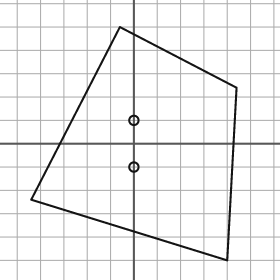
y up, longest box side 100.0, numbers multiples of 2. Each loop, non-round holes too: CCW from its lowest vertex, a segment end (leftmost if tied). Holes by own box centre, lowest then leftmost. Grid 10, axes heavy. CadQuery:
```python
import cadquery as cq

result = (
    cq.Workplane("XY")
    .moveTo(40.0, -50.0)
    .lineTo(44.0, 24.0)
    .lineTo(-6.0, 50.0)
    .lineTo(-44.0, -24.0)
    .close()
    .moveTo(0.0, -10.0)
    .circle(2.0)
    .moveTo(0.0, 10.0)
    .circle(2.0)
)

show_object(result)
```